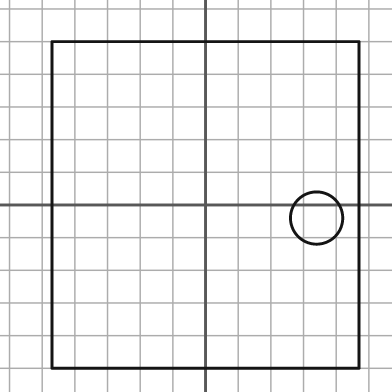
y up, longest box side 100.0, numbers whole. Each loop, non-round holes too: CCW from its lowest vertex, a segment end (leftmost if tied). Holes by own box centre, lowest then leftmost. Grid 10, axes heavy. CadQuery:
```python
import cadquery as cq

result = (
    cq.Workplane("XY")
    .moveTo(-47.0, -50.0)
    .lineTo(47.0, -50.0)
    .lineTo(47.0, 50.0)
    .lineTo(-47.0, 50.0)
    .close()
    .moveTo(34.0, -4.0)
    .circle(8.0)
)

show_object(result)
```